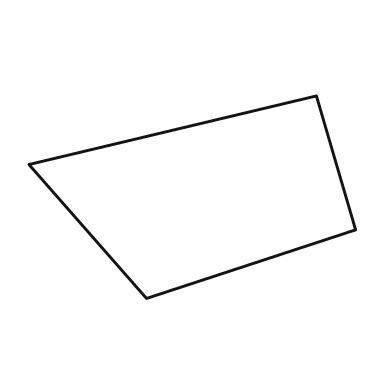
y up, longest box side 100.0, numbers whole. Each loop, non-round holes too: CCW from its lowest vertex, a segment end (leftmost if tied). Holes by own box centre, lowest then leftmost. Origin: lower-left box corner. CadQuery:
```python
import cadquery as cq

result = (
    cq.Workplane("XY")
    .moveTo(36.0, 0.0)
    .lineTo(100.0, 21.0)
    .lineTo(88.0, 62.0)
    .lineTo(0.0, 41.0)
    .close()
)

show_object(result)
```